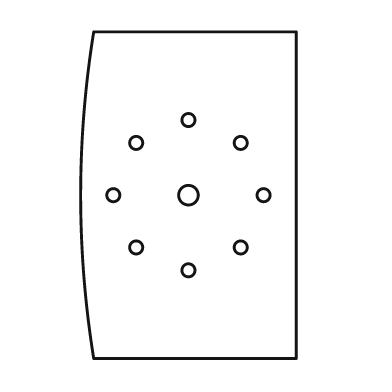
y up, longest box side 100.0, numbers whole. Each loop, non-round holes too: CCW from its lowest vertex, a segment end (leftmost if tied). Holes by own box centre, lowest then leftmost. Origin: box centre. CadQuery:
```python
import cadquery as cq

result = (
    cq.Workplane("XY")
    .moveTo(-29.0, -50.0)
    .lineTo(33.0, -50.0)
    .lineTo(33.0, 50.0)
    .lineTo(-29.0, 50.0)
    .threePointArc((-33.0, 0.0), (-29.0, -50.0))
    .close()
    .moveTo(0.0, -23.0)
    .circle(2.0)
    .moveTo(-16.0, -16.0)
    .circle(2.0)
    .moveTo(16.0, -16.0)
    .circle(2.0)
    .moveTo(-23.0, 0.0)
    .circle(2.0)
    .moveTo(0.0, 0.0)
    .circle(3.0)
    .moveTo(23.0, 0.0)
    .circle(2.0)
    .moveTo(-16.0, 16.0)
    .circle(2.0)
    .moveTo(16.0, 16.0)
    .circle(2.0)
    .moveTo(0.0, 23.0)
    .circle(2.0)
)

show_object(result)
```